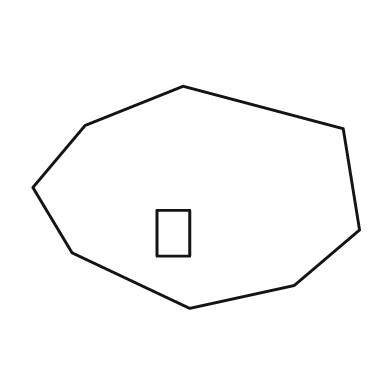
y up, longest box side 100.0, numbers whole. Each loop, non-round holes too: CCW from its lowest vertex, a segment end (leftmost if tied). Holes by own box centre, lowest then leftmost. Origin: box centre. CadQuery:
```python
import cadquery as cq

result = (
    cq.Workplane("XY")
    .moveTo(-2.0, -34.0)
    .lineTo(30.0, -27.0)
    .lineTo(50.0, -10.0)
    .lineTo(45.0, 21.0)
    .lineTo(-4.0, 34.0)
    .lineTo(-34.0, 22.0)
    .lineTo(-50.0, 3.0)
    .lineTo(-38.0, -17.0)
    .close()
    .moveTo(-12.0, -18.0)
    .lineTo(-2.0, -18.0)
    .lineTo(-2.0, -4.0)
    .lineTo(-12.0, -4.0)
    .close()
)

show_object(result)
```